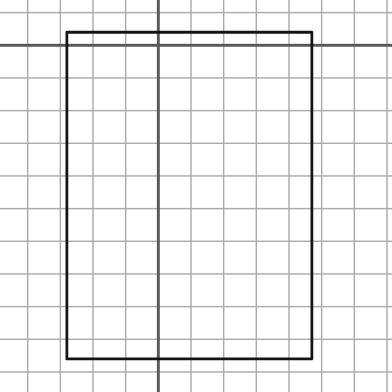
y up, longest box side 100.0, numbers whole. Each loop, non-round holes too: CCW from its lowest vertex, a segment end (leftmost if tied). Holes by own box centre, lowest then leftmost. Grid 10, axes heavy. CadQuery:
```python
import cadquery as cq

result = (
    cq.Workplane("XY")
    .moveTo(-28.0, -96.0)
    .lineTo(47.0, -96.0)
    .lineTo(47.0, 4.0)
    .lineTo(-28.0, 4.0)
    .close()
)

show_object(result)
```